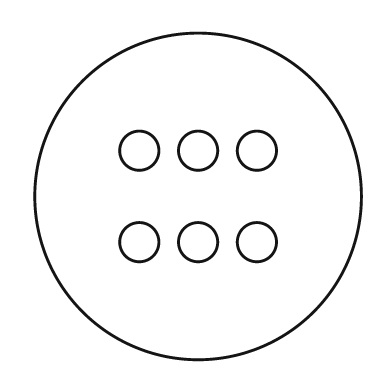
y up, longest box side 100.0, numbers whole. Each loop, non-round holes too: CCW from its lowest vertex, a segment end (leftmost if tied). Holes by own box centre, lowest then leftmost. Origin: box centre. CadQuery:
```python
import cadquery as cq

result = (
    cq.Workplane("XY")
    .moveTo(0.0, 0.0)
    .circle(50.0)
    .moveTo(-18.0, -14.0)
    .circle(6.0)
    .moveTo(0.0, -14.0)
    .circle(6.0)
    .moveTo(18.0, -14.0)
    .circle(6.0)
    .moveTo(-18.0, 14.0)
    .circle(6.0)
    .moveTo(0.0, 14.0)
    .circle(6.0)
    .moveTo(18.0, 14.0)
    .circle(6.0)
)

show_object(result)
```